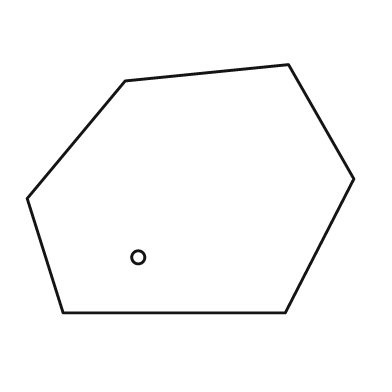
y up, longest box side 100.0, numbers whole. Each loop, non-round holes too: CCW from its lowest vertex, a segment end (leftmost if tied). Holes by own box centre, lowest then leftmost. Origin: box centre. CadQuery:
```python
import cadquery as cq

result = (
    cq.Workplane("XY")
    .moveTo(-39.0, -38.0)
    .lineTo(29.0, -38.0)
    .lineTo(50.0, 3.0)
    .lineTo(30.0, 38.0)
    .lineTo(-20.0, 33.0)
    .lineTo(-50.0, -3.0)
    .close()
    .moveTo(-16.0, -21.0)
    .circle(2.0)
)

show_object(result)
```